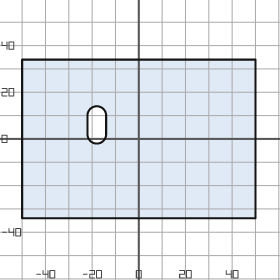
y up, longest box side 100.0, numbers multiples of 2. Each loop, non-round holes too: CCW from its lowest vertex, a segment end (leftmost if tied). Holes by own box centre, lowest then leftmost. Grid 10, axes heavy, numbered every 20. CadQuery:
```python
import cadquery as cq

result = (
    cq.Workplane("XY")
    .moveTo(-50.0, -34.0)
    .lineTo(50.0, -34.0)
    .lineTo(50.0, 34.0)
    .lineTo(-50.0, 34.0)
    .close()
    .moveTo(-22.0, 2.0)
    .threePointArc((-18.0, -2.0), (-14.0, 2.0))
    .lineTo(-14.0, 10.0)
    .threePointArc((-18.0, 14.0), (-22.0, 10.0))
    .close()
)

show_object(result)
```